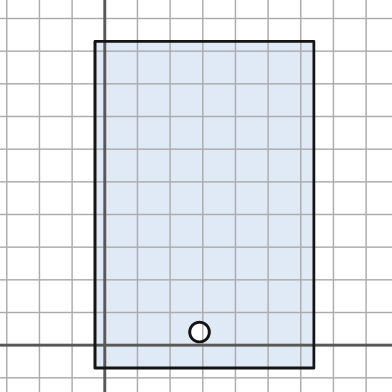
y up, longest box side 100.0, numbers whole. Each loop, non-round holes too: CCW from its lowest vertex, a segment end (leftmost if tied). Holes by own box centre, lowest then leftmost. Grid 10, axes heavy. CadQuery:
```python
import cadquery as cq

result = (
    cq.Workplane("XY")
    .moveTo(-3.0, -7.0)
    .lineTo(64.0, -7.0)
    .lineTo(64.0, 93.0)
    .lineTo(-3.0, 93.0)
    .close()
    .moveTo(29.0, 4.0)
    .circle(3.0)
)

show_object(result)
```